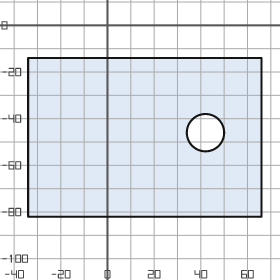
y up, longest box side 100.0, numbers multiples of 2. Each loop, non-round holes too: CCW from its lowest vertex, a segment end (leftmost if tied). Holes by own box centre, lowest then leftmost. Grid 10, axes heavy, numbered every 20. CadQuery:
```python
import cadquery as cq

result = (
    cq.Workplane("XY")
    .moveTo(-34.0, -82.0)
    .lineTo(66.0, -82.0)
    .lineTo(66.0, -14.0)
    .lineTo(-34.0, -14.0)
    .close()
    .moveTo(42.0, -46.0)
    .circle(8.0)
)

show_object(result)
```